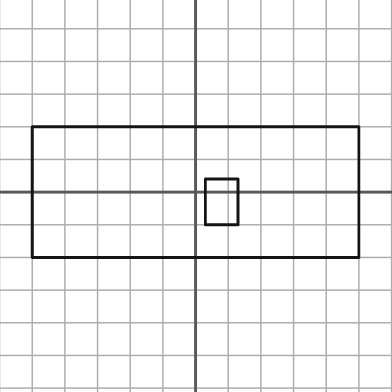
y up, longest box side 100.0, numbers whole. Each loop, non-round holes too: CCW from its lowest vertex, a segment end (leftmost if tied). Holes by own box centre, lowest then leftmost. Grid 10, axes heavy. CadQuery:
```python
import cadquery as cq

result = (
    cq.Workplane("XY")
    .moveTo(-50.0, -20.0)
    .lineTo(50.0, -20.0)
    .lineTo(50.0, 20.0)
    .lineTo(-50.0, 20.0)
    .close()
    .moveTo(3.0, -10.0)
    .lineTo(13.0, -10.0)
    .lineTo(13.0, 4.0)
    .lineTo(3.0, 4.0)
    .close()
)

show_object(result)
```